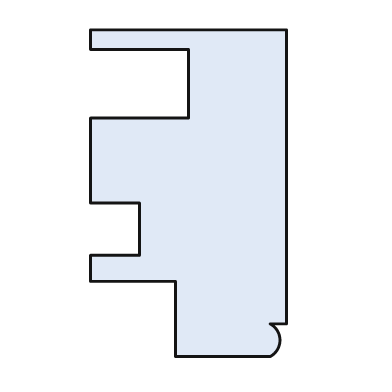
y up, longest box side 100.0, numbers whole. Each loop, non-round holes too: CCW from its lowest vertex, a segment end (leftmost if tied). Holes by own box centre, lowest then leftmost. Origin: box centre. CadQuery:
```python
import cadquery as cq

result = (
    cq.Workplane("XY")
    .moveTo(-4.0, -50.0)
    .lineTo(25.0, -50.0)
    .threePointArc((28.0, -45.0), (25.0, -40.0))
    .lineTo(30.0, -40.0)
    .lineTo(30.0, 50.0)
    .lineTo(-30.0, 50.0)
    .lineTo(-30.0, 44.0)
    .lineTo(0.0, 44.0)
    .lineTo(0.0, 23.0)
    .lineTo(-30.0, 23.0)
    .lineTo(-30.0, -3.0)
    .lineTo(-15.0, -3.0)
    .lineTo(-15.0, -19.0)
    .lineTo(-30.0, -19.0)
    .lineTo(-30.0, -27.0)
    .lineTo(-4.0, -27.0)
    .close()
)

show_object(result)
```